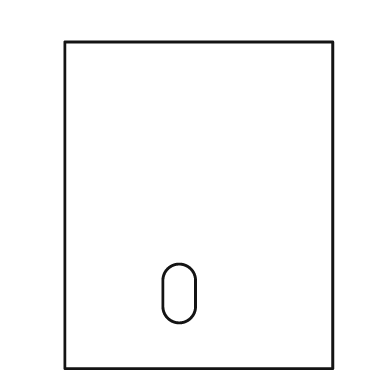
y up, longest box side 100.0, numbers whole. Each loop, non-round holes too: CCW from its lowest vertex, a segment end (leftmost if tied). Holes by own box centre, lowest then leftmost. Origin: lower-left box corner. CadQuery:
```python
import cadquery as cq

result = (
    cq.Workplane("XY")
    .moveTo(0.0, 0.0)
    .lineTo(82.0, 0.0)
    .lineTo(82.0, 100.0)
    .lineTo(0.0, 100.0)
    .close()
    .moveTo(30.0, 19.0)
    .threePointArc((35.0, 14.0), (40.0, 19.0))
    .lineTo(40.0, 27.0)
    .threePointArc((35.0, 32.0), (30.0, 27.0))
    .close()
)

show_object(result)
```